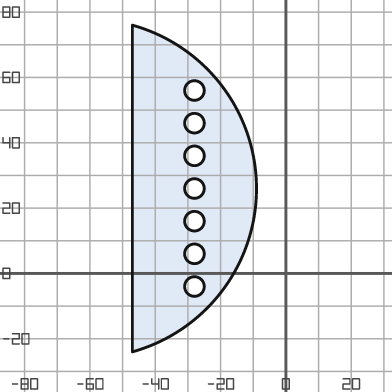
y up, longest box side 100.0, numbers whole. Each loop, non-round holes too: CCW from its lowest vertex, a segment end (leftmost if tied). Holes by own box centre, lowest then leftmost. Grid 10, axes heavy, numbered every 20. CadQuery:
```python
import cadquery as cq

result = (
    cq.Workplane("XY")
    .moveTo(-47.0, -24.0)
    .threePointArc((-9.0, 26.0), (-47.0, 76.0))
    .close()
    .moveTo(-28.0, -4.0)
    .circle(3.0)
    .moveTo(-28.0, 6.0)
    .circle(3.0)
    .moveTo(-28.0, 16.0)
    .circle(3.0)
    .moveTo(-28.0, 26.0)
    .circle(3.0)
    .moveTo(-28.0, 36.0)
    .circle(3.0)
    .moveTo(-28.0, 46.0)
    .circle(3.0)
    .moveTo(-28.0, 56.0)
    .circle(3.0)
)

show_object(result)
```